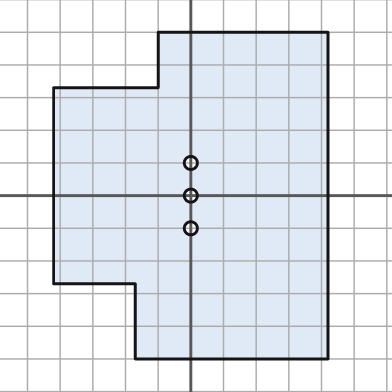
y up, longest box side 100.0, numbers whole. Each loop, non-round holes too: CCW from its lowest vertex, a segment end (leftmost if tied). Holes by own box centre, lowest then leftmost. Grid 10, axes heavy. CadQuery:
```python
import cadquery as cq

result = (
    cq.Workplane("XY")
    .moveTo(-17.0, -50.0)
    .lineTo(42.0, -50.0)
    .lineTo(42.0, 50.0)
    .lineTo(-10.0, 50.0)
    .lineTo(-10.0, 33.0)
    .lineTo(-42.0, 33.0)
    .lineTo(-42.0, -27.0)
    .lineTo(-17.0, -27.0)
    .close()
    .moveTo(0.0, -10.0)
    .circle(2.0)
    .moveTo(0.0, 0.0)
    .circle(2.0)
    .moveTo(0.0, 10.0)
    .circle(2.0)
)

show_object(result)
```